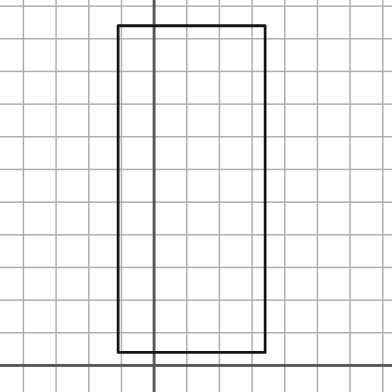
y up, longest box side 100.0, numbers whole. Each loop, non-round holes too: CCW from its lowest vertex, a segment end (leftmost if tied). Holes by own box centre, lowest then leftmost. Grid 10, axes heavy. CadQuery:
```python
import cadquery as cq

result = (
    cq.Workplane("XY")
    .moveTo(-11.0, 4.0)
    .lineTo(34.0, 4.0)
    .lineTo(34.0, 104.0)
    .lineTo(-11.0, 104.0)
    .close()
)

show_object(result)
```